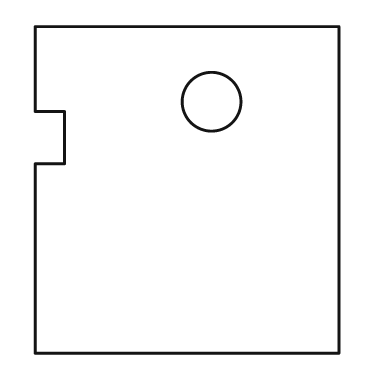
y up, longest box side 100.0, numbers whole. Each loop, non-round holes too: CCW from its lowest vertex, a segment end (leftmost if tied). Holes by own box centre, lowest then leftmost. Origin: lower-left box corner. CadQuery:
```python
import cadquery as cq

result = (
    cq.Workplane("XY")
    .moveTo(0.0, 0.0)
    .lineTo(93.0, 0.0)
    .lineTo(93.0, 100.0)
    .lineTo(0.0, 100.0)
    .lineTo(0.0, 74.0)
    .lineTo(9.0, 74.0)
    .lineTo(9.0, 58.0)
    .lineTo(0.0, 58.0)
    .close()
    .moveTo(54.0, 77.0)
    .circle(9.0)
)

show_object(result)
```